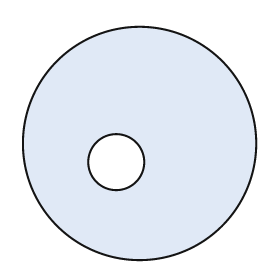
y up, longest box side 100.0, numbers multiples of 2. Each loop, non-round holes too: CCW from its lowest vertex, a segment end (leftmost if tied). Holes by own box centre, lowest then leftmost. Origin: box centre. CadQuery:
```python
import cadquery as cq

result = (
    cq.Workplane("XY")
    .moveTo(0.0, 0.0)
    .circle(50.0)
    .moveTo(-10.0, -8.0)
    .circle(12.0)
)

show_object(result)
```